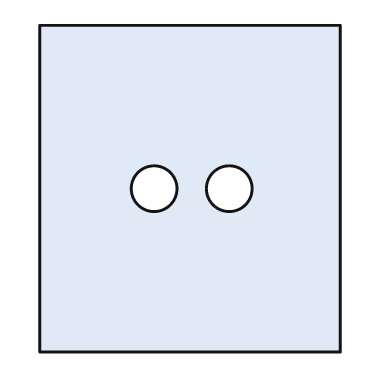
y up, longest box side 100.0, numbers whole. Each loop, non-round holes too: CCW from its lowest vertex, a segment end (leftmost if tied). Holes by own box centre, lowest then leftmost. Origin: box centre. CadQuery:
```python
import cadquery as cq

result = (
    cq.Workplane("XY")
    .moveTo(-46.0, -50.0)
    .lineTo(46.0, -50.0)
    .lineTo(46.0, 50.0)
    .lineTo(-46.0, 50.0)
    .close()
    .moveTo(-11.0, 0.0)
    .circle(7.0)
    .moveTo(12.0, 0.0)
    .circle(7.0)
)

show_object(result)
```